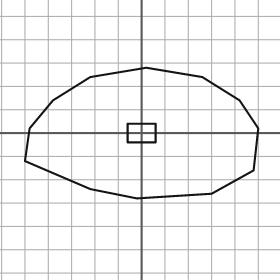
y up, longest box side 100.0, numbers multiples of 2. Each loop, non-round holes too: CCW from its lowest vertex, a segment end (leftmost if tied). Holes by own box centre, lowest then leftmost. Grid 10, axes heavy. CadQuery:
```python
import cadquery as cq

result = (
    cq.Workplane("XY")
    .moveTo(-2.0, -28.0)
    .lineTo(30.0, -26.0)
    .lineTo(48.0, -16.0)
    .lineTo(50.0, 2.0)
    .lineTo(42.0, 14.0)
    .lineTo(26.0, 24.0)
    .lineTo(2.0, 28.0)
    .lineTo(-22.0, 24.0)
    .lineTo(-38.0, 14.0)
    .lineTo(-48.0, 2.0)
    .lineTo(-50.0, -12.0)
    .lineTo(-22.0, -24.0)
    .close()
    .moveTo(-6.0, -4.0)
    .lineTo(6.0, -4.0)
    .lineTo(6.0, 4.0)
    .lineTo(-6.0, 4.0)
    .close()
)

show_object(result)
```